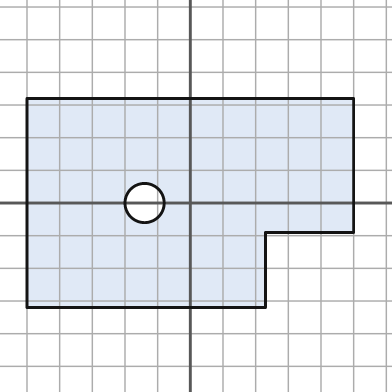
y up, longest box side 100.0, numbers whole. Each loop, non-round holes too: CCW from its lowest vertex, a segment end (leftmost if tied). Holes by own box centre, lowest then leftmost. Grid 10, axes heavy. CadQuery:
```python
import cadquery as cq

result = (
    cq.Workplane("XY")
    .moveTo(-50.0, -32.0)
    .lineTo(23.0, -32.0)
    .lineTo(23.0, -9.0)
    .lineTo(50.0, -9.0)
    .lineTo(50.0, 32.0)
    .lineTo(-50.0, 32.0)
    .close()
    .moveTo(-14.0, 0.0)
    .circle(6.0)
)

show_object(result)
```